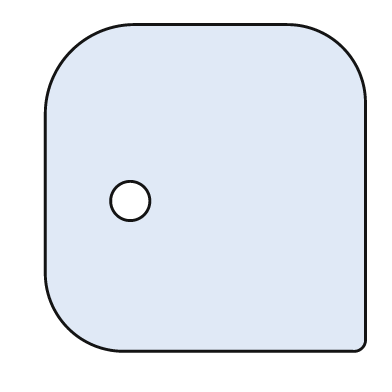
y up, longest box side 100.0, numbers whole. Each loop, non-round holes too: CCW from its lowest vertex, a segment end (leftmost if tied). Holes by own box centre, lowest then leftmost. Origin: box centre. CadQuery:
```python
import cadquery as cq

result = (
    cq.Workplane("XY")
    .moveTo(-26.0, -50.0)
    .lineTo(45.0, -50.0)
    .threePointArc((48.0, -49.0), (49.0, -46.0))
    .lineTo(49.0, 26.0)
    .threePointArc((42.0, 43.0), (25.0, 50.0))
    .lineTo(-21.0, 50.0)
    .threePointArc((-41.0, 42.0), (-49.0, 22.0))
    .lineTo(-49.0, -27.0)
    .threePointArc((-42.0, -43.0), (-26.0, -50.0))
    .close()
    .moveTo(-23.0, -4.0)
    .circle(6.0)
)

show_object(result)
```